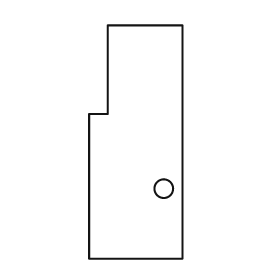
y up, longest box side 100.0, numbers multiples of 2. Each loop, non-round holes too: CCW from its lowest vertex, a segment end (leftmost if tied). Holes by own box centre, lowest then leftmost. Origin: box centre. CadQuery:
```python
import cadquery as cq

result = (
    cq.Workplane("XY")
    .moveTo(-20.0, -50.0)
    .lineTo(20.0, -50.0)
    .lineTo(20.0, 50.0)
    .lineTo(-12.0, 50.0)
    .lineTo(-12.0, 12.0)
    .lineTo(-20.0, 12.0)
    .close()
    .moveTo(12.0, -20.0)
    .circle(4.0)
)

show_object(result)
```